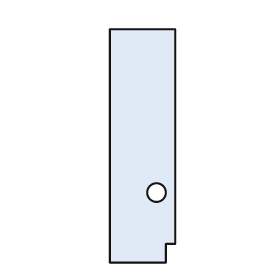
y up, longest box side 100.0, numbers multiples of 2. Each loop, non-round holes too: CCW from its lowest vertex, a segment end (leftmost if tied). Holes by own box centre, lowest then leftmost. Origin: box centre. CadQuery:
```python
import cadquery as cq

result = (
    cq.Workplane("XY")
    .moveTo(-14.0, -50.0)
    .lineTo(10.0, -50.0)
    .lineTo(10.0, -42.0)
    .lineTo(14.0, -42.0)
    .lineTo(14.0, 50.0)
    .lineTo(-14.0, 50.0)
    .close()
    .moveTo(6.0, -20.0)
    .circle(4.0)
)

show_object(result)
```